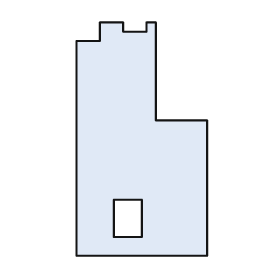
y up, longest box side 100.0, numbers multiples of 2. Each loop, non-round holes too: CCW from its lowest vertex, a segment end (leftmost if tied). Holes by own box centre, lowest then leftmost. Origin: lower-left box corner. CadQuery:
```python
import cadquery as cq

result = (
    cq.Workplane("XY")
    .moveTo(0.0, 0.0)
    .lineTo(56.0, 0.0)
    .lineTo(56.0, 58.0)
    .lineTo(34.0, 58.0)
    .lineTo(34.0, 100.0)
    .lineTo(30.0, 100.0)
    .lineTo(30.0, 96.0)
    .lineTo(20.0, 96.0)
    .lineTo(20.0, 100.0)
    .lineTo(10.0, 100.0)
    .lineTo(10.0, 92.0)
    .lineTo(0.0, 92.0)
    .close()
    .moveTo(16.0, 8.0)
    .lineTo(28.0, 8.0)
    .lineTo(28.0, 24.0)
    .lineTo(16.0, 24.0)
    .close()
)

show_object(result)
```